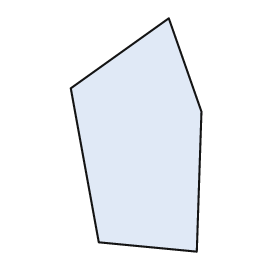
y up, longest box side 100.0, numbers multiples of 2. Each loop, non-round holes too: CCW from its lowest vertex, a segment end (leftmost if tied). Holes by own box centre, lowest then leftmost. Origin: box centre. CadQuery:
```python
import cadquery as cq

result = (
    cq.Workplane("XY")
    .moveTo(26.0, -50.0)
    .lineTo(28.0, 10.0)
    .lineTo(14.0, 50.0)
    .lineTo(-28.0, 20.0)
    .lineTo(-16.0, -46.0)
    .close()
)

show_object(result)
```